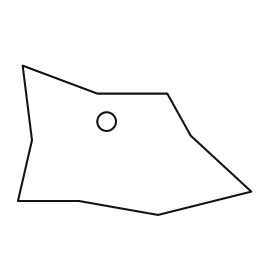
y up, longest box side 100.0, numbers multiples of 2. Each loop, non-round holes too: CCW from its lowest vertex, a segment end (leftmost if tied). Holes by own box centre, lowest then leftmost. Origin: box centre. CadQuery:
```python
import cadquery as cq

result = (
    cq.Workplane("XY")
    .moveTo(10.0, -32.0)
    .lineTo(50.0, -22.0)
    .lineTo(24.0, 2.0)
    .lineTo(14.0, 20.0)
    .lineTo(-16.0, 20.0)
    .lineTo(-48.0, 32.0)
    .lineTo(-44.0, 0.0)
    .lineTo(-50.0, -26.0)
    .lineTo(-24.0, -26.0)
    .close()
    .moveTo(-12.0, 8.0)
    .circle(4.0)
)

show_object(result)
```